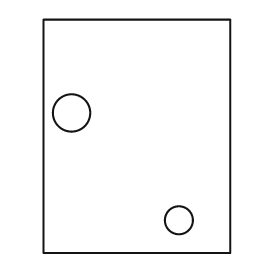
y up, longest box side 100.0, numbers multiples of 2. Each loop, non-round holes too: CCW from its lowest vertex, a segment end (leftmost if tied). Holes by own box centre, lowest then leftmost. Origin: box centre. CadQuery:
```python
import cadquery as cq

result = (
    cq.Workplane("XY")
    .moveTo(-40.0, -50.0)
    .lineTo(40.0, -50.0)
    .lineTo(40.0, 50.0)
    .lineTo(-40.0, 50.0)
    .close()
    .moveTo(18.0, -36.0)
    .circle(6.0)
    .moveTo(-28.0, 10.0)
    .circle(8.0)
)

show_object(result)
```